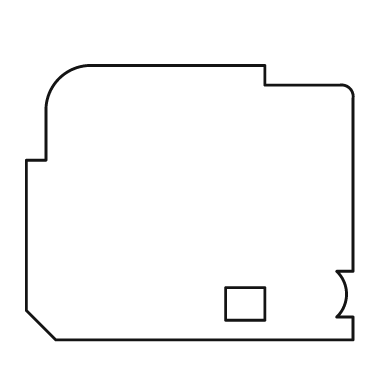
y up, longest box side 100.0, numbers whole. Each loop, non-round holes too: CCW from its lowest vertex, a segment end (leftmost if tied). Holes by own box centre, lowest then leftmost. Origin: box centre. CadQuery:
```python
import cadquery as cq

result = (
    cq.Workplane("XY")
    .moveTo(-41.0, -42.0)
    .lineTo(50.0, -42.0)
    .lineTo(50.0, -35.0)
    .lineTo(45.0, -35.0)
    .threePointArc((48.0, -28.0), (45.0, -21.0))
    .lineTo(50.0, -21.0)
    .lineTo(50.0, 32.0)
    .threePointArc((49.0, 35.0), (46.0, 36.0))
    .lineTo(23.0, 36.0)
    .lineTo(23.0, 42.0)
    .lineTo(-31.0, 42.0)
    .threePointArc((-40.0, 38.0), (-44.0, 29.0))
    .lineTo(-44.0, 13.0)
    .lineTo(-50.0, 13.0)
    .lineTo(-50.0, -33.0)
    .close()
    .moveTo(11.0, -36.0)
    .lineTo(23.0, -36.0)
    .lineTo(23.0, -26.0)
    .lineTo(11.0, -26.0)
    .close()
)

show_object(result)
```